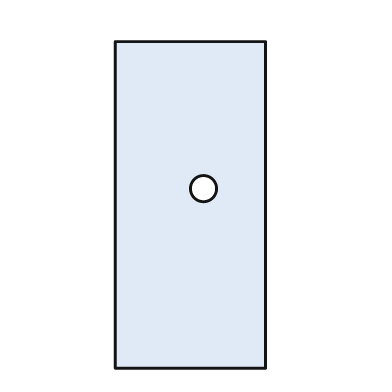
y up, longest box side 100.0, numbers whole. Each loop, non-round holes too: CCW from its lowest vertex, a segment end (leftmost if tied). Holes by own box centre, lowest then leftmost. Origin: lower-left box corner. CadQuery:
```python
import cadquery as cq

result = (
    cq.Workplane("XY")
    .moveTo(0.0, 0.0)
    .lineTo(46.0, 0.0)
    .lineTo(46.0, 100.0)
    .lineTo(0.0, 100.0)
    .close()
    .moveTo(27.0, 55.0)
    .circle(4.0)
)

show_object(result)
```